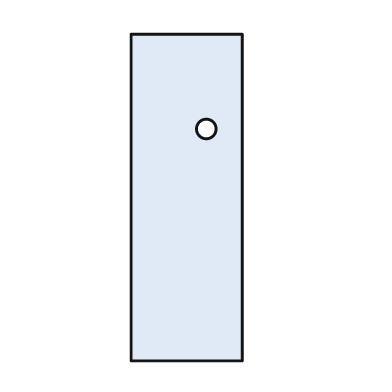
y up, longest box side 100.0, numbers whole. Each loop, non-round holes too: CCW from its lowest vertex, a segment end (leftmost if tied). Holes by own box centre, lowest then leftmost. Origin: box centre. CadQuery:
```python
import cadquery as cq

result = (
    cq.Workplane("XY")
    .moveTo(-17.0, -50.0)
    .lineTo(17.0, -50.0)
    .lineTo(17.0, 50.0)
    .lineTo(-17.0, 50.0)
    .close()
    .moveTo(6.0, 21.0)
    .circle(3.0)
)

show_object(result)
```